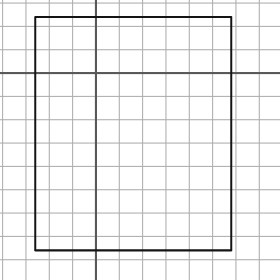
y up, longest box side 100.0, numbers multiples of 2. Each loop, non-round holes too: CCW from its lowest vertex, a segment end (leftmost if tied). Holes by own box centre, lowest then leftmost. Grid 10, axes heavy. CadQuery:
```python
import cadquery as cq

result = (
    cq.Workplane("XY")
    .moveTo(-26.0, -76.0)
    .lineTo(58.0, -76.0)
    .lineTo(58.0, 24.0)
    .lineTo(-26.0, 24.0)
    .close()
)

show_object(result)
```